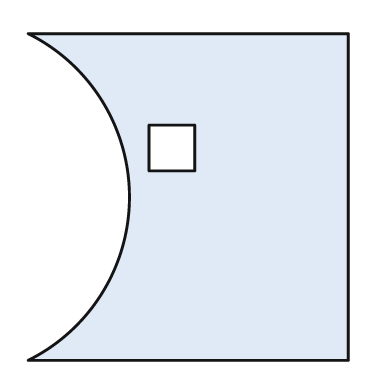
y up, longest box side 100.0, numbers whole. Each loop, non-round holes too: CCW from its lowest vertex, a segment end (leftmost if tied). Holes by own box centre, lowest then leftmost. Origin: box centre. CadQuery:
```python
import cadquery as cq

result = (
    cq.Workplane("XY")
    .moveTo(-49.0, -50.0)
    .lineTo(49.0, -50.0)
    .lineTo(49.0, 50.0)
    .lineTo(-49.0, 50.0)
    .threePointArc((-18.0, 0.0), (-49.0, -50.0))
    .close()
    .moveTo(-12.0, 8.0)
    .lineTo(2.0, 8.0)
    .lineTo(2.0, 22.0)
    .lineTo(-12.0, 22.0)
    .close()
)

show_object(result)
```